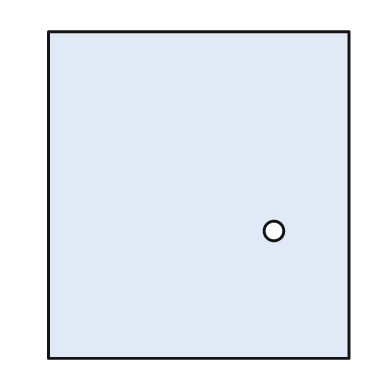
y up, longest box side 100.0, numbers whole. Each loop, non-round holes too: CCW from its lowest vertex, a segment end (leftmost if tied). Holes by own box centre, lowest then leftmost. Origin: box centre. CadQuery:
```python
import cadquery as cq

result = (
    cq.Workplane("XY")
    .moveTo(-46.0, -50.0)
    .lineTo(46.0, -50.0)
    .lineTo(46.0, 50.0)
    .lineTo(-46.0, 50.0)
    .close()
    .moveTo(23.0, -11.0)
    .circle(3.0)
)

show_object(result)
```